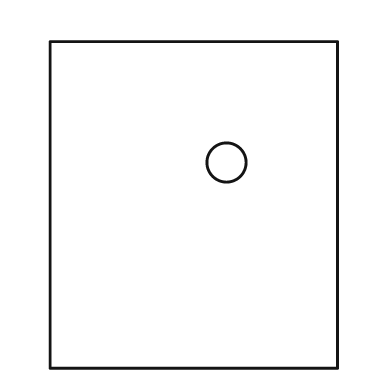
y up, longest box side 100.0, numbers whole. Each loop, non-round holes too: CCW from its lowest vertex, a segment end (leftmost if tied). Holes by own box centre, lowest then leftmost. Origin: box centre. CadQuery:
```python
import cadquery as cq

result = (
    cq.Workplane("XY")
    .moveTo(-44.0, -50.0)
    .lineTo(44.0, -50.0)
    .lineTo(44.0, 50.0)
    .lineTo(-44.0, 50.0)
    .close()
    .moveTo(10.0, 13.0)
    .circle(6.0)
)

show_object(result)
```